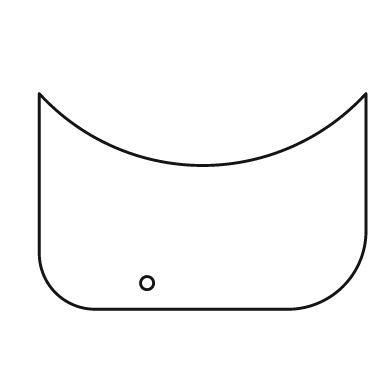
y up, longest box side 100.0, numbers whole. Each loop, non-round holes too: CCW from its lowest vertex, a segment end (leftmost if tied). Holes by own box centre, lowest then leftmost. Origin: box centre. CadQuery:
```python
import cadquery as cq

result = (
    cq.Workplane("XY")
    .moveTo(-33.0, -33.0)
    .lineTo(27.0, -33.0)
    .threePointArc((43.0, -26.0), (50.0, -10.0))
    .lineTo(50.0, 33.0)
    .threePointArc((0.0, 11.0), (-50.0, 33.0))
    .lineTo(-50.0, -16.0)
    .threePointArc((-45.0, -28.0), (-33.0, -33.0))
    .close()
    .moveTo(-17.0, -25.0)
    .circle(2.0)
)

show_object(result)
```